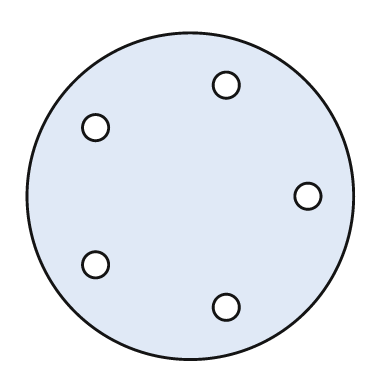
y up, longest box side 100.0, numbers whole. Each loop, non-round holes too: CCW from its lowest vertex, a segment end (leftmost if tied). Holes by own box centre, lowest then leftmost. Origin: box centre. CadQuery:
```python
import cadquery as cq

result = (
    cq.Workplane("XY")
    .moveTo(0.0, 0.0)
    .circle(50.0)
    .moveTo(11.0, -34.0)
    .circle(4.0)
    .moveTo(-29.0, -21.0)
    .circle(4.0)
    .moveTo(36.0, 0.0)
    .circle(4.0)
    .moveTo(-29.0, 21.0)
    .circle(4.0)
    .moveTo(11.0, 34.0)
    .circle(4.0)
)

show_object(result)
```